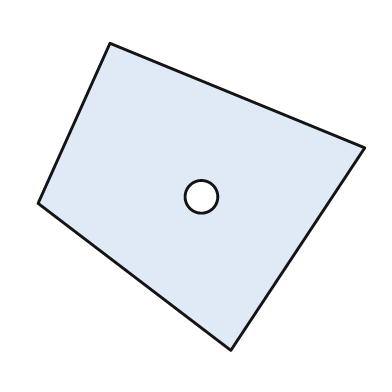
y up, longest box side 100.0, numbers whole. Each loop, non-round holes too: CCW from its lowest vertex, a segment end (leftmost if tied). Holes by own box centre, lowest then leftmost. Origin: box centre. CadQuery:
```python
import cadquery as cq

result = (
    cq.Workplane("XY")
    .moveTo(9.0, -47.0)
    .lineTo(50.0, 15.0)
    .lineTo(-28.0, 47.0)
    .lineTo(-50.0, -2.0)
    .close()
    .moveTo(0.0, 0.0)
    .circle(5.0)
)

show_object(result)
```